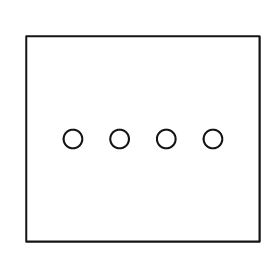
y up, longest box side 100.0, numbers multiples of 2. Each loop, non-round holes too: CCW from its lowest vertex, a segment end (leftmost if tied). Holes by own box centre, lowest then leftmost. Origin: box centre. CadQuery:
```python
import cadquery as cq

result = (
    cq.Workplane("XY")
    .moveTo(-50.0, -44.0)
    .lineTo(50.0, -44.0)
    .lineTo(50.0, 44.0)
    .lineTo(-50.0, 44.0)
    .close()
    .moveTo(-30.0, 0.0)
    .circle(4.0)
    .moveTo(-10.0, 0.0)
    .circle(4.0)
    .moveTo(10.0, 0.0)
    .circle(4.0)
    .moveTo(30.0, 0.0)
    .circle(4.0)
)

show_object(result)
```